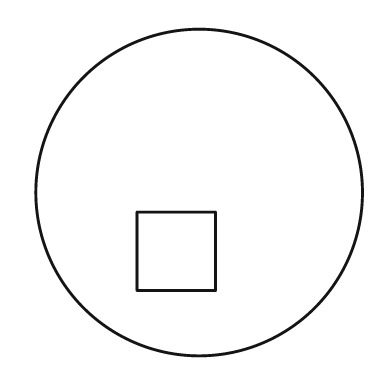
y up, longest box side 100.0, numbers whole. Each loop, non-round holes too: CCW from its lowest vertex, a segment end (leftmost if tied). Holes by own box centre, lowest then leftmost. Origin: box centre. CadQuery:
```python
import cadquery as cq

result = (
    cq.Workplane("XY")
    .moveTo(0.0, 0.0)
    .circle(50.0)
    .moveTo(-19.0, -30.0)
    .lineTo(5.0, -30.0)
    .lineTo(5.0, -6.0)
    .lineTo(-19.0, -6.0)
    .close()
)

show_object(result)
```